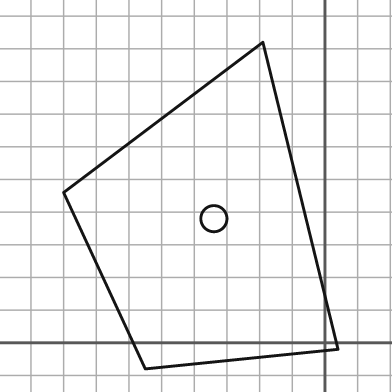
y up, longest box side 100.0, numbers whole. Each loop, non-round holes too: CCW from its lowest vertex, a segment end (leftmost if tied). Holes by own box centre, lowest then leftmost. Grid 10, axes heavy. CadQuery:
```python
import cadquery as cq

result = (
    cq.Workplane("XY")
    .moveTo(-55.0, -8.0)
    .lineTo(4.0, -2.0)
    .lineTo(-19.0, 92.0)
    .lineTo(-80.0, 46.0)
    .close()
    .moveTo(-34.0, 38.0)
    .circle(4.0)
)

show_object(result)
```